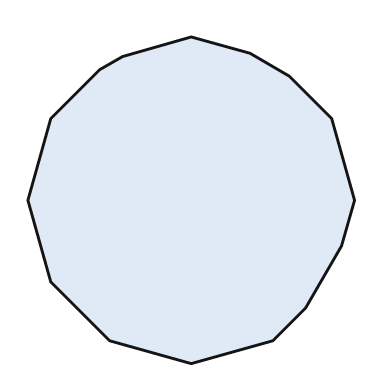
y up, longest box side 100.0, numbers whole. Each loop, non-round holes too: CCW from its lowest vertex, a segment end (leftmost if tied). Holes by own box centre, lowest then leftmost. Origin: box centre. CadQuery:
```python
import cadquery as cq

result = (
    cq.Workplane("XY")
    .moveTo(0.0, -50.0)
    .lineTo(25.0, -43.0)
    .lineTo(35.0, -33.0)
    .lineTo(46.0, -14.0)
    .lineTo(50.0, 0.0)
    .lineTo(43.0, 25.0)
    .lineTo(30.0, 38.0)
    .lineTo(18.0, 45.0)
    .lineTo(0.0, 50.0)
    .lineTo(-21.0, 44.0)
    .lineTo(-28.0, 40.0)
    .lineTo(-43.0, 25.0)
    .lineTo(-50.0, 0.0)
    .lineTo(-43.0, -25.0)
    .lineTo(-25.0, -43.0)
    .close()
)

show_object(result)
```